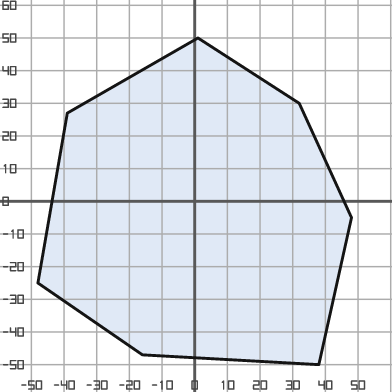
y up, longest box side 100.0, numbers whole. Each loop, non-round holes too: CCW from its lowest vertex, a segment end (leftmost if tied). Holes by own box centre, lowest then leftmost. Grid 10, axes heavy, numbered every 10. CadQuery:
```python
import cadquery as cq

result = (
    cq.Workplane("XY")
    .moveTo(38.0, -50.0)
    .lineTo(48.0, -5.0)
    .lineTo(32.0, 30.0)
    .lineTo(1.0, 50.0)
    .lineTo(-39.0, 27.0)
    .lineTo(-48.0, -25.0)
    .lineTo(-16.0, -47.0)
    .close()
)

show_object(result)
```